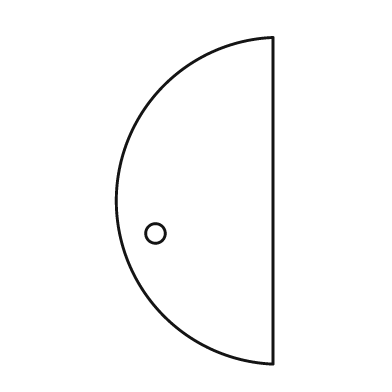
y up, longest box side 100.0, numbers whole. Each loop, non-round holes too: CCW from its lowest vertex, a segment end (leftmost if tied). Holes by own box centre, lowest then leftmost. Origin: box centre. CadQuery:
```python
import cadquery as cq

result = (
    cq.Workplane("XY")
    .moveTo(24.0, -50.0)
    .lineTo(24.0, 50.0)
    .threePointArc((-24.0, 0.0), (24.0, -50.0))
    .close()
    .moveTo(-12.0, -10.0)
    .circle(3.0)
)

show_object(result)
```